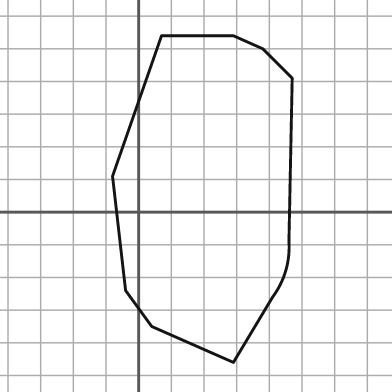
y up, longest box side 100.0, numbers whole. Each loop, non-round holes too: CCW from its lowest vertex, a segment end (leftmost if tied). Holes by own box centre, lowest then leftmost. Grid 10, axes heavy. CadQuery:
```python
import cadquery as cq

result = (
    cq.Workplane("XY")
    .moveTo(29.0, -46.0)
    .lineTo(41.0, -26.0)
    .threePointArc((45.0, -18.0), (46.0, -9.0))
    .lineTo(47.0, 41.0)
    .lineTo(38.0, 50.0)
    .lineTo(29.0, 54.0)
    .lineTo(7.0, 54.0)
    .lineTo(-8.0, 11.0)
    .lineTo(-4.0, -24.0)
    .lineTo(4.0, -35.0)
    .close()
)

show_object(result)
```